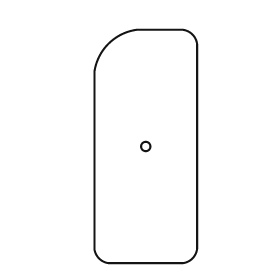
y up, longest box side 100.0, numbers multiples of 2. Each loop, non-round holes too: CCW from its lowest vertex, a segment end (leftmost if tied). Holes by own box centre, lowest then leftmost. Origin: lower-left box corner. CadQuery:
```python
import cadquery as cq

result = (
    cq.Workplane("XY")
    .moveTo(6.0, 0.0)
    .lineTo(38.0, 0.0)
    .threePointArc((42.0, 2.0), (44.0, 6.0))
    .lineTo(44.0, 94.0)
    .threePointArc((42.0, 98.0), (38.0, 100.0))
    .lineTo(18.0, 100.0)
    .threePointArc((6.0, 94.0), (0.0, 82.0))
    .lineTo(0.0, 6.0)
    .threePointArc((2.0, 2.0), (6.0, 0.0))
    .close()
    .moveTo(22.0, 50.0)
    .circle(2.0)
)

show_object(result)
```